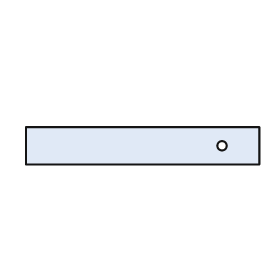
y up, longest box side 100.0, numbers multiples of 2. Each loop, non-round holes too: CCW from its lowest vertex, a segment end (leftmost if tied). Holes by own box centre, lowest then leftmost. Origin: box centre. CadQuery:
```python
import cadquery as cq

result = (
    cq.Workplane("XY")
    .moveTo(-50.0, -8.0)
    .lineTo(50.0, -8.0)
    .lineTo(50.0, 8.0)
    .lineTo(-50.0, 8.0)
    .close()
    .moveTo(34.0, 0.0)
    .circle(2.0)
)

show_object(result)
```